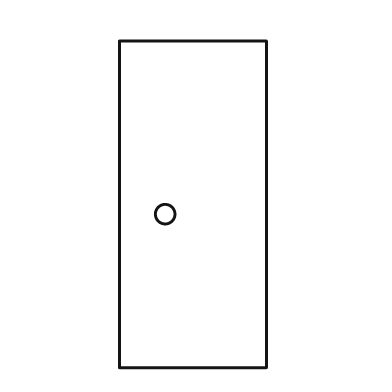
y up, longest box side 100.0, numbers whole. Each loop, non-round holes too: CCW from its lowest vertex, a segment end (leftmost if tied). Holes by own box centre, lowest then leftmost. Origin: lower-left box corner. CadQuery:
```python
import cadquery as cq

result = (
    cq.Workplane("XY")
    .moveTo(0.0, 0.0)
    .lineTo(45.0, 0.0)
    .lineTo(45.0, 100.0)
    .lineTo(0.0, 100.0)
    .close()
    .moveTo(14.0, 47.0)
    .circle(3.0)
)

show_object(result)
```